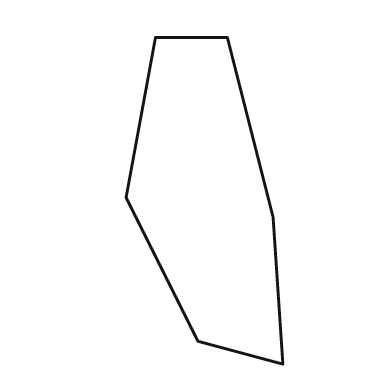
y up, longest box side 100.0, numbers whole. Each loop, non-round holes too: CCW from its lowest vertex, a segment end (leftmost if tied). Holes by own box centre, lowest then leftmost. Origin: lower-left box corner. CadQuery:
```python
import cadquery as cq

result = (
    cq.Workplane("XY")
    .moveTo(48.0, 0.0)
    .lineTo(45.0, 45.0)
    .lineTo(31.0, 100.0)
    .lineTo(9.0, 100.0)
    .lineTo(0.0, 51.0)
    .lineTo(22.0, 7.0)
    .close()
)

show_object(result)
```